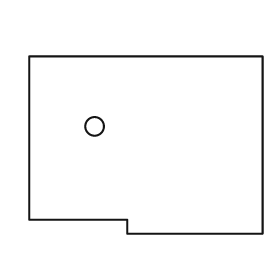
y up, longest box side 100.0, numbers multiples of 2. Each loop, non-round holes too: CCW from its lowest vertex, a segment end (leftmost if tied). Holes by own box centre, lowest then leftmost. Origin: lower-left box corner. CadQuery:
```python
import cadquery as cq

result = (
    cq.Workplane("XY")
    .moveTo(42.0, 0.0)
    .lineTo(100.0, 0.0)
    .lineTo(100.0, 76.0)
    .lineTo(0.0, 76.0)
    .lineTo(0.0, 6.0)
    .lineTo(42.0, 6.0)
    .close()
    .moveTo(28.0, 46.0)
    .circle(4.0)
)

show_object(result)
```